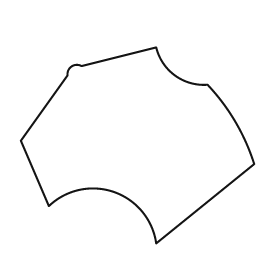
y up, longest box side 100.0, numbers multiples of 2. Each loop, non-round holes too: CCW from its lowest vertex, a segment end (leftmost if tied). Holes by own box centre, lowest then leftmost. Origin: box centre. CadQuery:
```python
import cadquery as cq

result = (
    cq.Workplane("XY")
    .moveTo(8.0, -42.0)
    .lineTo(50.0, -8.0)
    .threePointArc((42.0, 10.0), (30.0, 26.0))
    .threePointArc((16.0, 30.0), (8.0, 42.0))
    .lineTo(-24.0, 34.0)
    .threePointArc((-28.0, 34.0), (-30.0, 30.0))
    .lineTo(-50.0, 2.0)
    .lineTo(-38.0, -26.0)
    .threePointArc((-10.0, -20.0), (8.0, -42.0))
    .close()
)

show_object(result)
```